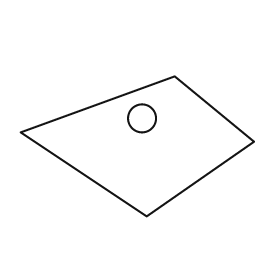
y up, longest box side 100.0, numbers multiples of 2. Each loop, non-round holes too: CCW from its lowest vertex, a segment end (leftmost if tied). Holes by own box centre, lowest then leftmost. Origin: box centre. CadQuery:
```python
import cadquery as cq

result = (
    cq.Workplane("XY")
    .moveTo(4.0, -30.0)
    .lineTo(50.0, 2.0)
    .lineTo(16.0, 30.0)
    .lineTo(-50.0, 6.0)
    .close()
    .moveTo(2.0, 12.0)
    .circle(6.0)
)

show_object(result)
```